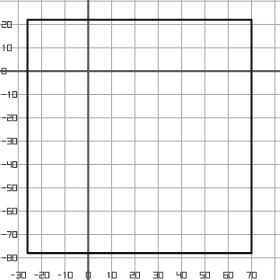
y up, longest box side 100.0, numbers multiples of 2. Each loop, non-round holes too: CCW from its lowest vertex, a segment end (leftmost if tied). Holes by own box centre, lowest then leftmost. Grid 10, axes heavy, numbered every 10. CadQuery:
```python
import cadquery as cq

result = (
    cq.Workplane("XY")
    .moveTo(-26.0, -78.0)
    .lineTo(70.0, -78.0)
    .lineTo(70.0, 22.0)
    .lineTo(-26.0, 22.0)
    .close()
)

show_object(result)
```